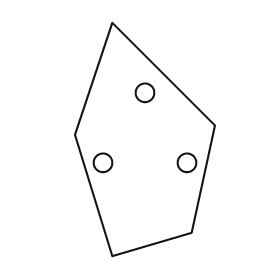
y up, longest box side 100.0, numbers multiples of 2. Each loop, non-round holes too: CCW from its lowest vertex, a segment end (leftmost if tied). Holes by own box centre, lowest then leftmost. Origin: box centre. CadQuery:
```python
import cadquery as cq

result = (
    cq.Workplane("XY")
    .moveTo(-14.0, -50.0)
    .lineTo(20.0, -40.0)
    .lineTo(30.0, 6.0)
    .lineTo(-14.0, 50.0)
    .lineTo(-30.0, 2.0)
    .close()
    .moveTo(-18.0, -10.0)
    .circle(4.0)
    .moveTo(18.0, -10.0)
    .circle(4.0)
    .moveTo(0.0, 20.0)
    .circle(4.0)
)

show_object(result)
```